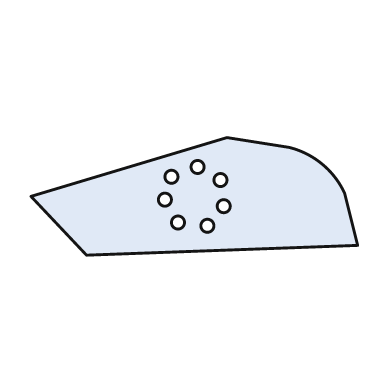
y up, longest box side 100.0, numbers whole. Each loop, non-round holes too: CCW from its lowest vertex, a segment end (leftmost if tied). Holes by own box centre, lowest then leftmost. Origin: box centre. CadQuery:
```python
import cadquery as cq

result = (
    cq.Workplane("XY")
    .moveTo(-33.0, -18.0)
    .lineTo(50.0, -15.0)
    .lineTo(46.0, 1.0)
    .threePointArc((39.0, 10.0), (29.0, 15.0))
    .lineTo(10.0, 18.0)
    .lineTo(-50.0, 0.0)
    .close()
    .moveTo(4.0, -9.0)
    .circle(2.0)
    .moveTo(-5.0, -8.0)
    .circle(2.0)
    .moveTo(9.0, -3.0)
    .circle(2.0)
    .moveTo(-9.0, -1.0)
    .circle(2.0)
    .moveTo(8.0, 5.0)
    .circle(2.0)
    .moveTo(-7.0, 6.0)
    .circle(2.0)
    .moveTo(1.0, 9.0)
    .circle(2.0)
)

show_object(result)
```